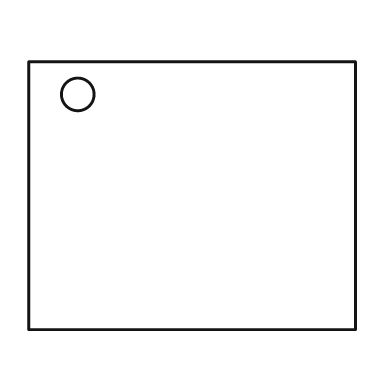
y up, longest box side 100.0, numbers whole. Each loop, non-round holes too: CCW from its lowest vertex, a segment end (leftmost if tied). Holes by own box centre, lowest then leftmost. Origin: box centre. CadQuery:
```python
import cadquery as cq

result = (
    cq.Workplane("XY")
    .moveTo(-50.0, -41.0)
    .lineTo(50.0, -41.0)
    .lineTo(50.0, 41.0)
    .lineTo(-50.0, 41.0)
    .close()
    .moveTo(-35.0, 31.0)
    .circle(5.0)
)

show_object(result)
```